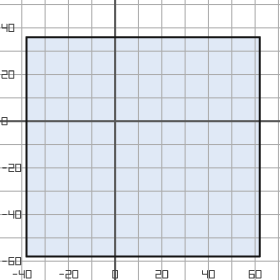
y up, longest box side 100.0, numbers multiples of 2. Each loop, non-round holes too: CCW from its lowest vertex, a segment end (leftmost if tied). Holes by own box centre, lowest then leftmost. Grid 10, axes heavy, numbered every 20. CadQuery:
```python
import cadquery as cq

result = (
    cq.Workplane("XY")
    .moveTo(-38.0, -58.0)
    .lineTo(62.0, -58.0)
    .lineTo(62.0, 36.0)
    .lineTo(-38.0, 36.0)
    .close()
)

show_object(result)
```